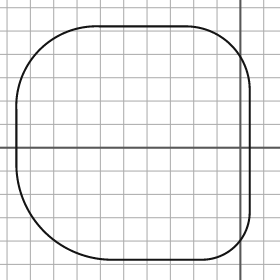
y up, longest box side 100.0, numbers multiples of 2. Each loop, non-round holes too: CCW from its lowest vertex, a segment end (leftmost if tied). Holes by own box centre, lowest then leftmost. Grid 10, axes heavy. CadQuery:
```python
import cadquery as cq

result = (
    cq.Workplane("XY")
    .moveTo(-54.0, -48.0)
    .lineTo(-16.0, -48.0)
    .threePointArc((-2.0, -42.0), (4.0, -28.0))
    .lineTo(4.0, 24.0)
    .threePointArc((-4.0, 44.0), (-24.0, 52.0))
    .lineTo(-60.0, 52.0)
    .threePointArc((-86.0, 42.0), (-96.0, 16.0))
    .lineTo(-96.0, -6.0)
    .threePointArc((-84.0, -36.0), (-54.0, -48.0))
    .close()
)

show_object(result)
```